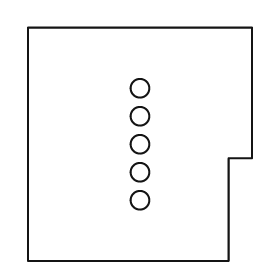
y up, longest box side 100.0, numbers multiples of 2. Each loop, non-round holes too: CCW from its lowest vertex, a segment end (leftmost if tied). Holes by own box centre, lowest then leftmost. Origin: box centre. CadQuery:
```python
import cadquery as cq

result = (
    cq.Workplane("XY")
    .moveTo(-48.0, -50.0)
    .lineTo(38.0, -50.0)
    .lineTo(38.0, -6.0)
    .lineTo(48.0, -6.0)
    .lineTo(48.0, 50.0)
    .lineTo(-48.0, 50.0)
    .close()
    .moveTo(0.0, -24.0)
    .circle(4.0)
    .moveTo(0.0, -12.0)
    .circle(4.0)
    .moveTo(0.0, 0.0)
    .circle(4.0)
    .moveTo(0.0, 12.0)
    .circle(4.0)
    .moveTo(0.0, 24.0)
    .circle(4.0)
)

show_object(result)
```